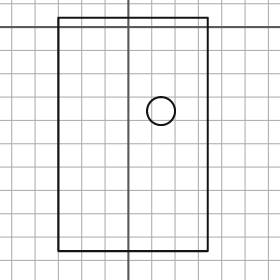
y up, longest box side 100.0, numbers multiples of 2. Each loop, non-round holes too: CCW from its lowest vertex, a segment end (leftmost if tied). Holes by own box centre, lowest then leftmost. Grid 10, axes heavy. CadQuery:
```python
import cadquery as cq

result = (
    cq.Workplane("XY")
    .moveTo(-30.0, -96.0)
    .lineTo(34.0, -96.0)
    .lineTo(34.0, 4.0)
    .lineTo(-30.0, 4.0)
    .close()
    .moveTo(14.0, -36.0)
    .circle(6.0)
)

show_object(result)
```